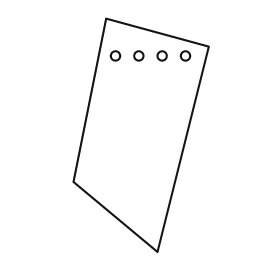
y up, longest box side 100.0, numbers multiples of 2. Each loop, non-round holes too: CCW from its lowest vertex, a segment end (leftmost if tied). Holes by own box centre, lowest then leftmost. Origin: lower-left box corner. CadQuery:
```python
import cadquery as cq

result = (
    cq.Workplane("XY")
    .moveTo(36.0, 0.0)
    .lineTo(58.0, 88.0)
    .lineTo(14.0, 100.0)
    .lineTo(0.0, 30.0)
    .close()
    .moveTo(18.0, 84.0)
    .circle(2.0)
    .moveTo(28.0, 84.0)
    .circle(2.0)
    .moveTo(38.0, 84.0)
    .circle(2.0)
    .moveTo(48.0, 84.0)
    .circle(2.0)
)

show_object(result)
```